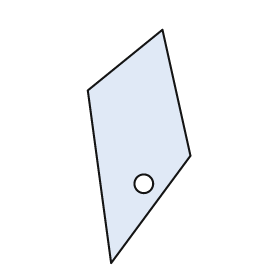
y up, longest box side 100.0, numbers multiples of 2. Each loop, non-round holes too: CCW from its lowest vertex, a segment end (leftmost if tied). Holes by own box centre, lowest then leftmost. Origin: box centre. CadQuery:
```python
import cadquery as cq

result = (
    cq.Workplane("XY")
    .moveTo(-12.0, -50.0)
    .lineTo(22.0, -4.0)
    .lineTo(10.0, 50.0)
    .lineTo(-22.0, 24.0)
    .close()
    .moveTo(2.0, -16.0)
    .circle(4.0)
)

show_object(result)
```